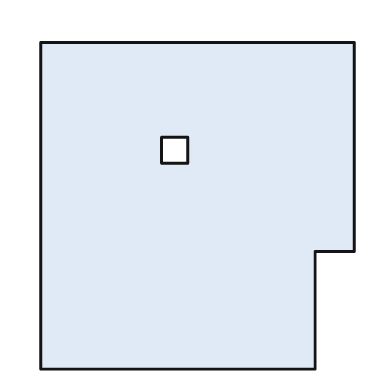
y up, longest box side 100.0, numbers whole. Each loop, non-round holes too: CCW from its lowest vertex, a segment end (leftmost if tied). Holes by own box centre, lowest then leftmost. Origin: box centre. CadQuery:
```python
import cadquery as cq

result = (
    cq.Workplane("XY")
    .moveTo(-48.0, -50.0)
    .lineTo(36.0, -50.0)
    .lineTo(36.0, -14.0)
    .lineTo(48.0, -14.0)
    .lineTo(48.0, 50.0)
    .lineTo(-48.0, 50.0)
    .close()
    .moveTo(-11.0, 13.0)
    .lineTo(-3.0, 13.0)
    .lineTo(-3.0, 21.0)
    .lineTo(-11.0, 21.0)
    .close()
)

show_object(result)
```